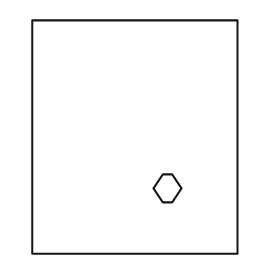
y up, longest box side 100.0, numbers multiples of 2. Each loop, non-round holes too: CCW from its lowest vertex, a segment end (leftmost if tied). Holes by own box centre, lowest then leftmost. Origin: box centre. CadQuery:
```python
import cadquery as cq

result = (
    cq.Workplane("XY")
    .moveTo(-44.0, -50.0)
    .lineTo(44.0, -50.0)
    .lineTo(44.0, 50.0)
    .lineTo(-44.0, 50.0)
    .close()
    .moveTo(12.0, -28.0)
    .lineTo(16.0, -28.0)
    .lineTo(20.0, -22.0)
    .lineTo(16.0, -16.0)
    .lineTo(12.0, -16.0)
    .lineTo(8.0, -22.0)
    .close()
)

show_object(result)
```